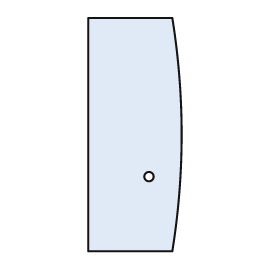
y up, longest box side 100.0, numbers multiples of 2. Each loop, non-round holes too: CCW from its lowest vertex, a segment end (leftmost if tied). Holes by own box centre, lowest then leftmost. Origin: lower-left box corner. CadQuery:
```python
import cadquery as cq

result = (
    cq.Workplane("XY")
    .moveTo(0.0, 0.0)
    .lineTo(36.0, 0.0)
    .threePointArc((40.0, 50.0), (36.0, 100.0))
    .lineTo(0.0, 100.0)
    .close()
    .moveTo(26.0, 32.0)
    .circle(2.0)
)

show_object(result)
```